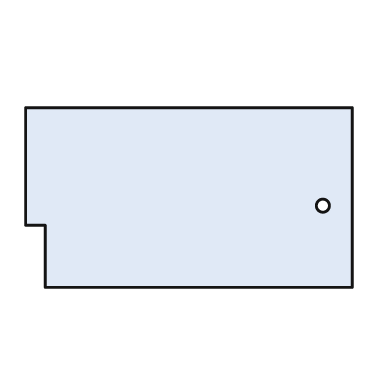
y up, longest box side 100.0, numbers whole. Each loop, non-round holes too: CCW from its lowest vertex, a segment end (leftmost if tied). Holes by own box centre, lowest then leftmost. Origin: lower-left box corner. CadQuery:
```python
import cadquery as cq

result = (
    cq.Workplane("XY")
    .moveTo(6.0, 0.0)
    .lineTo(100.0, 0.0)
    .lineTo(100.0, 55.0)
    .lineTo(0.0, 55.0)
    .lineTo(0.0, 19.0)
    .lineTo(6.0, 19.0)
    .close()
    .moveTo(91.0, 25.0)
    .circle(2.0)
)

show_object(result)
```